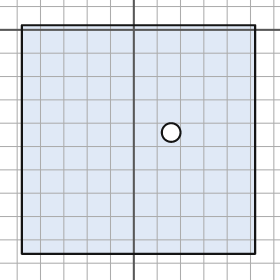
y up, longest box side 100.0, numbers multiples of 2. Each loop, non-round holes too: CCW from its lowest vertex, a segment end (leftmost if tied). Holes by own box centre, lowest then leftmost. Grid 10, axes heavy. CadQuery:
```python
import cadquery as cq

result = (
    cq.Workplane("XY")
    .moveTo(-48.0, -96.0)
    .lineTo(52.0, -96.0)
    .lineTo(52.0, 2.0)
    .lineTo(-48.0, 2.0)
    .close()
    .moveTo(16.0, -44.0)
    .circle(4.0)
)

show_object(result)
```